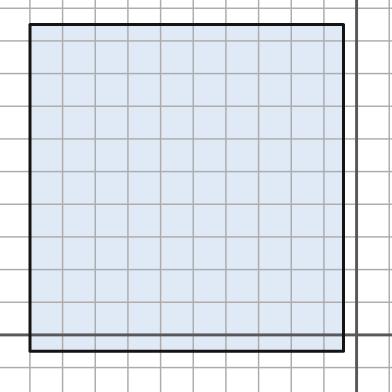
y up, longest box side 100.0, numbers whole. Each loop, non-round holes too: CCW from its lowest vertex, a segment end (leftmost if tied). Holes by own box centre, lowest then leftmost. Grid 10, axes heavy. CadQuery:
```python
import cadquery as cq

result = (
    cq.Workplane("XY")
    .moveTo(-100.0, -5.0)
    .lineTo(-4.0, -5.0)
    .lineTo(-4.0, 95.0)
    .lineTo(-100.0, 95.0)
    .close()
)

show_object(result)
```